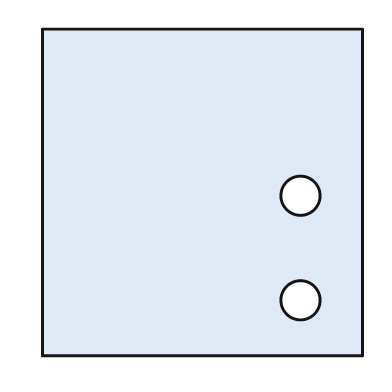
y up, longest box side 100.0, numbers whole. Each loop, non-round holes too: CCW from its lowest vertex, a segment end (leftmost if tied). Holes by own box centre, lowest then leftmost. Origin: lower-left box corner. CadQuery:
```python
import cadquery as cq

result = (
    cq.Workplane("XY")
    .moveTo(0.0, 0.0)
    .lineTo(98.0, 0.0)
    .lineTo(98.0, 100.0)
    .lineTo(0.0, 100.0)
    .close()
    .moveTo(79.0, 17.0)
    .circle(6.0)
    .moveTo(79.0, 49.0)
    .circle(6.0)
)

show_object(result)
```